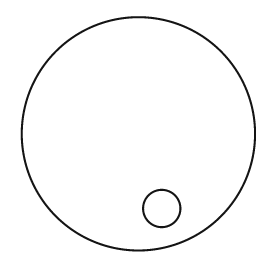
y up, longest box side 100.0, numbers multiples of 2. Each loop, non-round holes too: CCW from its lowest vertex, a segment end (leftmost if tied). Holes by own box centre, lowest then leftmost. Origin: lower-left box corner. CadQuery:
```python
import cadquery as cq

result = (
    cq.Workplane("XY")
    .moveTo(50.0, 50.0)
    .circle(50.0)
    .moveTo(60.0, 18.0)
    .circle(8.0)
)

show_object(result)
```